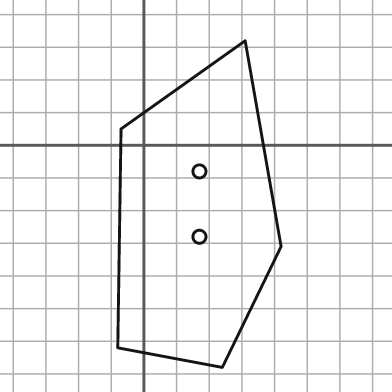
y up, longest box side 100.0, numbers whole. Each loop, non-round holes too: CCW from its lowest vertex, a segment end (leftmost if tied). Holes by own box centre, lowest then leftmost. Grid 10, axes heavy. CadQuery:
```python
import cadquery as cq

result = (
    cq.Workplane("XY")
    .moveTo(24.0, -68.0)
    .lineTo(42.0, -31.0)
    .lineTo(31.0, 32.0)
    .lineTo(-7.0, 5.0)
    .lineTo(-8.0, -62.0)
    .close()
    .moveTo(17.0, -28.0)
    .circle(2.0)
    .moveTo(17.0, -8.0)
    .circle(2.0)
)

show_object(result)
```